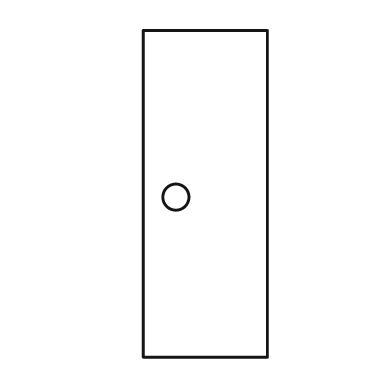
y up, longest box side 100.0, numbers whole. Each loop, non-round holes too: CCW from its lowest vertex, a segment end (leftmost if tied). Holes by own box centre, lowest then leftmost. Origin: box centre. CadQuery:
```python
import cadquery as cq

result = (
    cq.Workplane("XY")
    .moveTo(-19.0, -50.0)
    .lineTo(19.0, -50.0)
    .lineTo(19.0, 50.0)
    .lineTo(-19.0, 50.0)
    .close()
    .moveTo(-9.0, -1.0)
    .circle(4.0)
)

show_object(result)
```